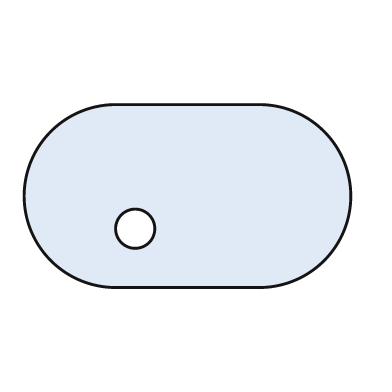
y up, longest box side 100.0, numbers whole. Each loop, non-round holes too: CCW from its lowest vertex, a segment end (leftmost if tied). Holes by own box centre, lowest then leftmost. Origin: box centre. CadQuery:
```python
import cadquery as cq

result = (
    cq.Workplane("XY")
    .moveTo(-22.0, -28.0)
    .lineTo(22.0, -28.0)
    .threePointArc((50.0, 0.0), (22.0, 28.0))
    .lineTo(-22.0, 28.0)
    .threePointArc((-50.0, 0.0), (-22.0, -28.0))
    .close()
    .moveTo(-16.0, -10.0)
    .circle(6.0)
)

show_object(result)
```